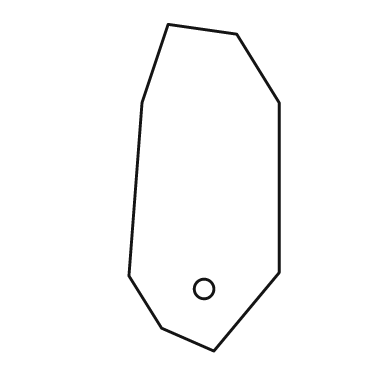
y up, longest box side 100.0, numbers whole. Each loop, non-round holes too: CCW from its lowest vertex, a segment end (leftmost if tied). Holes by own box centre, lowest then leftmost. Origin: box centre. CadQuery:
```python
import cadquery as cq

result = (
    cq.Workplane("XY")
    .moveTo(3.0, -50.0)
    .lineTo(23.0, -26.0)
    .lineTo(23.0, 26.0)
    .lineTo(10.0, 47.0)
    .lineTo(-11.0, 50.0)
    .lineTo(-19.0, 26.0)
    .lineTo(-23.0, -27.0)
    .lineTo(-13.0, -43.0)
    .close()
    .moveTo(0.0, -31.0)
    .circle(3.0)
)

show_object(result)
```